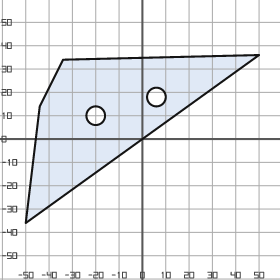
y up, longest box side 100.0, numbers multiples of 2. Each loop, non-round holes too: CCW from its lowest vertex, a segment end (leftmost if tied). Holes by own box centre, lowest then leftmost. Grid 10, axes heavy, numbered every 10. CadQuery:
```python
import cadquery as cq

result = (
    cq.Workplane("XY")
    .moveTo(-50.0, -36.0)
    .lineTo(50.0, 36.0)
    .lineTo(-34.0, 34.0)
    .lineTo(-44.0, 14.0)
    .close()
    .moveTo(-20.0, 10.0)
    .circle(4.0)
    .moveTo(6.0, 18.0)
    .circle(4.0)
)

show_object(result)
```